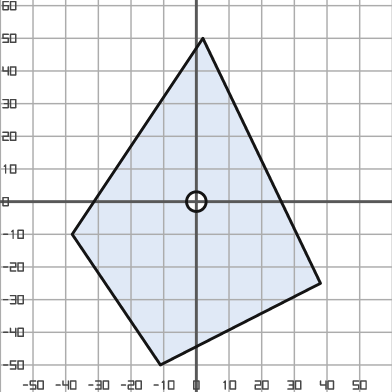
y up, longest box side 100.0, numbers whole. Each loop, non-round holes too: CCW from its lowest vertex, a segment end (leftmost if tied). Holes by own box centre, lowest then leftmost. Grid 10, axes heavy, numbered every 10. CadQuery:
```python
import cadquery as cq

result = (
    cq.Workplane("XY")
    .moveTo(-11.0, -50.0)
    .lineTo(38.0, -25.0)
    .lineTo(2.0, 50.0)
    .lineTo(-38.0, -10.0)
    .close()
    .moveTo(0.0, 0.0)
    .circle(3.0)
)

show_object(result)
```